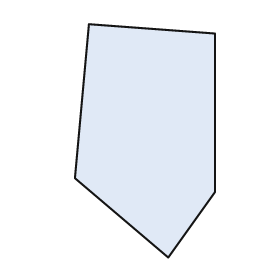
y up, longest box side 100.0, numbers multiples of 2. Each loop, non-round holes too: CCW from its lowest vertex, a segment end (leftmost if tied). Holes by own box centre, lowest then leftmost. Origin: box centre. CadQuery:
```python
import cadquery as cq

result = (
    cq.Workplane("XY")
    .moveTo(10.0, -50.0)
    .lineTo(30.0, -22.0)
    .lineTo(30.0, 46.0)
    .lineTo(-24.0, 50.0)
    .lineTo(-30.0, -16.0)
    .close()
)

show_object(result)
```